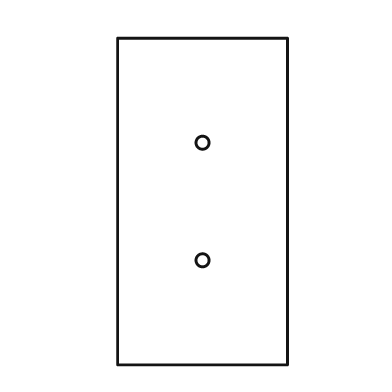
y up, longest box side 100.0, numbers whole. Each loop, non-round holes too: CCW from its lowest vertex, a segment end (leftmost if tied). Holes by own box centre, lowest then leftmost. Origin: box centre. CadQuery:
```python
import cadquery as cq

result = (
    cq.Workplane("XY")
    .moveTo(-26.0, -50.0)
    .lineTo(26.0, -50.0)
    .lineTo(26.0, 50.0)
    .lineTo(-26.0, 50.0)
    .close()
    .moveTo(0.0, -18.0)
    .circle(2.0)
    .moveTo(0.0, 18.0)
    .circle(2.0)
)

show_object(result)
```